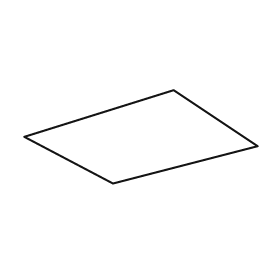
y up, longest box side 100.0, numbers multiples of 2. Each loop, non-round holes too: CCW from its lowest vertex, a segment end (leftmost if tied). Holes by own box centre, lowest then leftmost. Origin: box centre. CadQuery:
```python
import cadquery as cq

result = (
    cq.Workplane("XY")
    .moveTo(-12.0, -20.0)
    .lineTo(50.0, -4.0)
    .lineTo(14.0, 20.0)
    .lineTo(-50.0, 0.0)
    .close()
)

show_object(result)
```